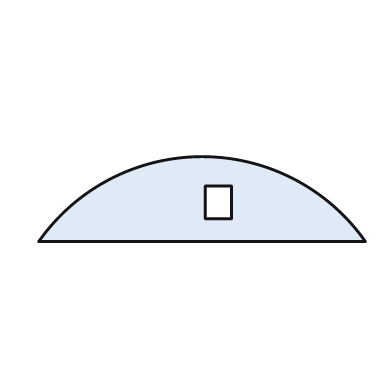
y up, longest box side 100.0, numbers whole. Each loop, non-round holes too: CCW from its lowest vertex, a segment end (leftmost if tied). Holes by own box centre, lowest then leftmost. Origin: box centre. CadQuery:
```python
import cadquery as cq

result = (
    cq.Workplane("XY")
    .moveTo(-50.0, -13.0)
    .lineTo(50.0, -13.0)
    .threePointArc((0.0, 13.0), (-50.0, -13.0))
    .close()
    .moveTo(1.0, -6.0)
    .lineTo(9.0, -6.0)
    .lineTo(9.0, 4.0)
    .lineTo(1.0, 4.0)
    .close()
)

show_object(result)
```